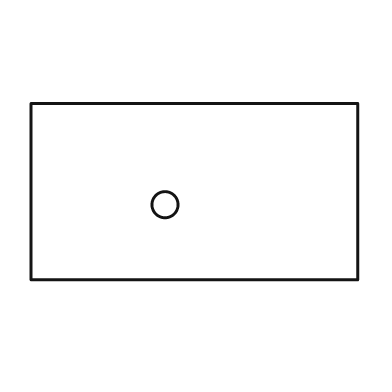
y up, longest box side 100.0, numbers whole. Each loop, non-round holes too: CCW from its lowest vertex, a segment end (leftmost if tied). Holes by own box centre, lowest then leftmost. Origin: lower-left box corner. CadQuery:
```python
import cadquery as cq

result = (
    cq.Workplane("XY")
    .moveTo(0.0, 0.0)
    .lineTo(100.0, 0.0)
    .lineTo(100.0, 54.0)
    .lineTo(0.0, 54.0)
    .close()
    .moveTo(41.0, 23.0)
    .circle(4.0)
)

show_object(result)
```